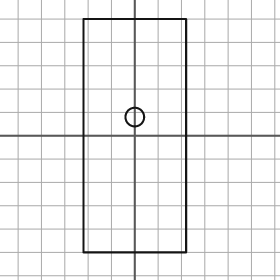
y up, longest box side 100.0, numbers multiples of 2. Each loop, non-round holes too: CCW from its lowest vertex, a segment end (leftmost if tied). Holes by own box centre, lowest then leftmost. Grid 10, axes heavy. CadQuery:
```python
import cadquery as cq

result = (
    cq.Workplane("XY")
    .moveTo(-22.0, -50.0)
    .lineTo(22.0, -50.0)
    .lineTo(22.0, 50.0)
    .lineTo(-22.0, 50.0)
    .close()
    .moveTo(0.0, 8.0)
    .circle(4.0)
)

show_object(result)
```